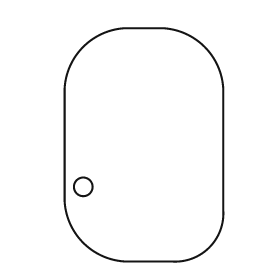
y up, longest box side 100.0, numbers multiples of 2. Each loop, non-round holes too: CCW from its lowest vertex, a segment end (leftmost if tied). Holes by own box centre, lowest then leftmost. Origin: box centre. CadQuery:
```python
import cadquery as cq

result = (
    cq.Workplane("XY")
    .moveTo(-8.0, -50.0)
    .lineTo(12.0, -50.0)
    .threePointArc((28.0, -44.0), (34.0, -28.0))
    .lineTo(34.0, 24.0)
    .threePointArc((26.0, 42.0), (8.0, 50.0))
    .lineTo(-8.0, 50.0)
    .threePointArc((-26.0, 42.0), (-34.0, 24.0))
    .lineTo(-34.0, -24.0)
    .threePointArc((-26.0, -42.0), (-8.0, -50.0))
    .close()
    .moveTo(-26.0, -18.0)
    .circle(4.0)
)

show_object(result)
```